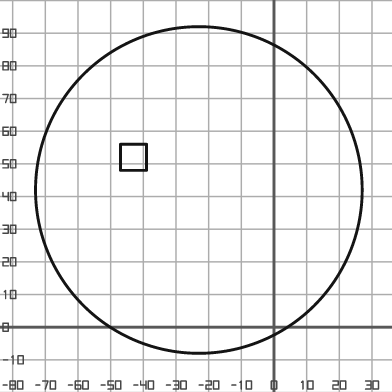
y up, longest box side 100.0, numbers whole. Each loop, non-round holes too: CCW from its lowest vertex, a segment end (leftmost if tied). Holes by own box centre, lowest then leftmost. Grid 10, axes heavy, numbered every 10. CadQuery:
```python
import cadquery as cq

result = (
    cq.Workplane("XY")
    .moveTo(-23.0, 42.0)
    .circle(50.0)
    .moveTo(-47.0, 48.0)
    .lineTo(-39.0, 48.0)
    .lineTo(-39.0, 56.0)
    .lineTo(-47.0, 56.0)
    .close()
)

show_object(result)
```